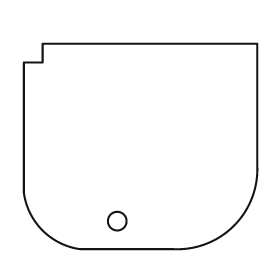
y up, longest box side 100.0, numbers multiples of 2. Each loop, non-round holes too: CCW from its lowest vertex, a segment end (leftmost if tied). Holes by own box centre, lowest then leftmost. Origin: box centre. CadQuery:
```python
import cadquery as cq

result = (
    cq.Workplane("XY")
    .moveTo(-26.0, -44.0)
    .lineTo(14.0, -44.0)
    .threePointArc((40.0, -34.0), (50.0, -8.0))
    .lineTo(50.0, 44.0)
    .lineTo(-42.0, 44.0)
    .lineTo(-42.0, 36.0)
    .lineTo(-50.0, 36.0)
    .lineTo(-50.0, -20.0)
    .threePointArc((-42.0, -36.0), (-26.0, -44.0))
    .close()
    .moveTo(-10.0, -32.0)
    .circle(4.0)
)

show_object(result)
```